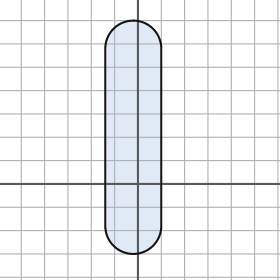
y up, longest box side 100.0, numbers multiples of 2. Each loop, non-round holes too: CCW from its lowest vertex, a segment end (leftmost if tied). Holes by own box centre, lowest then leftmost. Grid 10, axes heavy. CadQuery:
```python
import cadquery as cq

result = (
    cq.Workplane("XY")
    .moveTo(-14.0, -18.0)
    .threePointArc((-2.0, -30.0), (10.0, -18.0))
    .lineTo(10.0, 58.0)
    .threePointArc((-2.0, 70.0), (-14.0, 58.0))
    .close()
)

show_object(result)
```